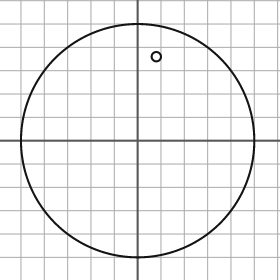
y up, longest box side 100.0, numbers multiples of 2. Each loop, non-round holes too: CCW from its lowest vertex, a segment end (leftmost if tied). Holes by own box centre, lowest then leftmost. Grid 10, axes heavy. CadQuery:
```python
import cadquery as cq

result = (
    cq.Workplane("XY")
    .moveTo(0.0, 0.0)
    .circle(50.0)
    .moveTo(8.0, 36.0)
    .circle(2.0)
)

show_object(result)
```